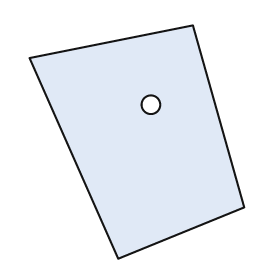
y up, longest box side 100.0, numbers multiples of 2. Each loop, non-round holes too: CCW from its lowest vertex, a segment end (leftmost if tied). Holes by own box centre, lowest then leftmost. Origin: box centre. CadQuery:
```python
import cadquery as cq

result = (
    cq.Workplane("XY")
    .moveTo(-8.0, -50.0)
    .lineTo(46.0, -28.0)
    .lineTo(24.0, 50.0)
    .lineTo(-46.0, 36.0)
    .close()
    .moveTo(6.0, 16.0)
    .circle(4.0)
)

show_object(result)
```